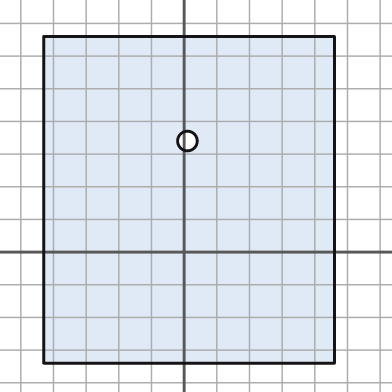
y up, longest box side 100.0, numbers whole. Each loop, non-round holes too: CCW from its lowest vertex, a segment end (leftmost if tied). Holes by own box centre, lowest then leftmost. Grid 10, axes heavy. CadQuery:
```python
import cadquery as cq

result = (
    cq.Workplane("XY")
    .moveTo(-43.0, -34.0)
    .lineTo(46.0, -34.0)
    .lineTo(46.0, 66.0)
    .lineTo(-43.0, 66.0)
    .close()
    .moveTo(1.0, 34.0)
    .circle(3.0)
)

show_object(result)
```